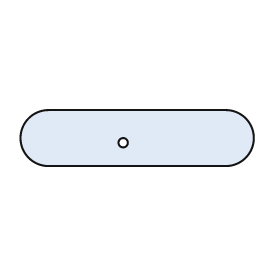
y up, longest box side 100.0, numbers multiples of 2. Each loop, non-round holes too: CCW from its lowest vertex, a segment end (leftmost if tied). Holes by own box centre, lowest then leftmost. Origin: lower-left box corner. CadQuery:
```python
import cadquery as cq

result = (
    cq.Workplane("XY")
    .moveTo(12.0, 0.0)
    .lineTo(88.0, 0.0)
    .threePointArc((100.0, 12.0), (88.0, 24.0))
    .lineTo(12.0, 24.0)
    .threePointArc((0.0, 12.0), (12.0, 0.0))
    .close()
    .moveTo(44.0, 10.0)
    .circle(2.0)
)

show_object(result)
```